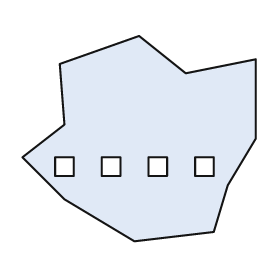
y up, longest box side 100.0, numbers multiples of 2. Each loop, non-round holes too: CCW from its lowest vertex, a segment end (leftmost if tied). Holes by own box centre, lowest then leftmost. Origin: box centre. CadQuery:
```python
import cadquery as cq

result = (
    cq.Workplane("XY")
    .moveTo(-2.0, -44.0)
    .lineTo(32.0, -40.0)
    .lineTo(38.0, -20.0)
    .lineTo(50.0, 0.0)
    .lineTo(50.0, 34.0)
    .lineTo(20.0, 28.0)
    .lineTo(0.0, 44.0)
    .lineTo(-34.0, 32.0)
    .lineTo(-32.0, 6.0)
    .lineTo(-50.0, -8.0)
    .lineTo(-32.0, -26.0)
    .close()
    .moveTo(-36.0, -16.0)
    .lineTo(-28.0, -16.0)
    .lineTo(-28.0, -8.0)
    .lineTo(-36.0, -8.0)
    .close()
    .moveTo(-16.0, -16.0)
    .lineTo(-8.0, -16.0)
    .lineTo(-8.0, -8.0)
    .lineTo(-16.0, -8.0)
    .close()
    .moveTo(4.0, -16.0)
    .lineTo(12.0, -16.0)
    .lineTo(12.0, -8.0)
    .lineTo(4.0, -8.0)
    .close()
    .moveTo(24.0, -16.0)
    .lineTo(32.0, -16.0)
    .lineTo(32.0, -8.0)
    .lineTo(24.0, -8.0)
    .close()
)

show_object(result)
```